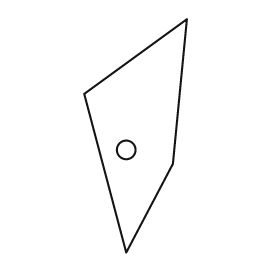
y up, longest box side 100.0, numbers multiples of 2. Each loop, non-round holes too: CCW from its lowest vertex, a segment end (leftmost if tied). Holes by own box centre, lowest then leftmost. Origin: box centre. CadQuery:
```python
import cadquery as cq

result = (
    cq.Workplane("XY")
    .moveTo(-4.0, -50.0)
    .lineTo(16.0, -12.0)
    .lineTo(22.0, 50.0)
    .lineTo(-22.0, 18.0)
    .close()
    .moveTo(-4.0, -6.0)
    .circle(4.0)
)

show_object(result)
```